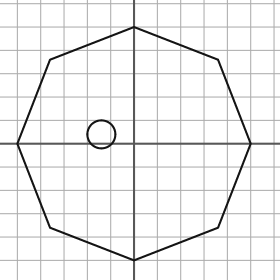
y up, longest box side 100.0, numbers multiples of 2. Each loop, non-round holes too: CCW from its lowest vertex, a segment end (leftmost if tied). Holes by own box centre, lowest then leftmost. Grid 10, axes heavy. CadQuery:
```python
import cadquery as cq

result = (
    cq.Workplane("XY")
    .moveTo(0.0, -50.0)
    .lineTo(36.0, -36.0)
    .lineTo(50.0, 0.0)
    .lineTo(36.0, 36.0)
    .lineTo(0.0, 50.0)
    .lineTo(-36.0, 36.0)
    .lineTo(-50.0, 0.0)
    .lineTo(-36.0, -36.0)
    .close()
    .moveTo(-14.0, 4.0)
    .circle(6.0)
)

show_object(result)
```